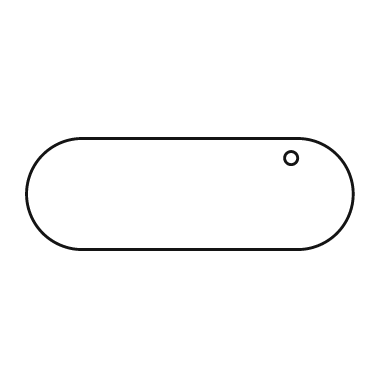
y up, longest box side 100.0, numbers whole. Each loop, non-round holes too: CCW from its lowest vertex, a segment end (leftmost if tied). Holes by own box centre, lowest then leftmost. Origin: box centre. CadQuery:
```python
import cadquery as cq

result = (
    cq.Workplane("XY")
    .moveTo(-33.0, -17.0)
    .lineTo(33.0, -17.0)
    .threePointArc((50.0, 0.0), (33.0, 17.0))
    .lineTo(-33.0, 17.0)
    .threePointArc((-50.0, 0.0), (-33.0, -17.0))
    .close()
    .moveTo(31.0, 11.0)
    .circle(2.0)
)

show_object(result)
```